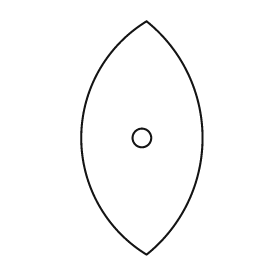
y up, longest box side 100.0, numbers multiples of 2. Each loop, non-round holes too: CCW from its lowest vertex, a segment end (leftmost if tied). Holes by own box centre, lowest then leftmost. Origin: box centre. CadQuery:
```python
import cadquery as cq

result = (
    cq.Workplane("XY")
    .moveTo(2.0, -50.0)
    .threePointArc((26.0, 0.0), (2.0, 50.0))
    .threePointArc((-26.0, 0.0), (2.0, -50.0))
    .close()
    .moveTo(0.0, 0.0)
    .circle(4.0)
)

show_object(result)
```